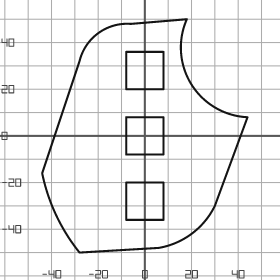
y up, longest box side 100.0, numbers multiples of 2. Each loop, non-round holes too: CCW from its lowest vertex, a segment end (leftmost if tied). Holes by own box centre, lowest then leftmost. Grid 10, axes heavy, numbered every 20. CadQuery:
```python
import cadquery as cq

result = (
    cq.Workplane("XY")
    .moveTo(-28.0, -50.0)
    .lineTo(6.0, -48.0)
    .threePointArc((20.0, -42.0), (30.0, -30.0))
    .lineTo(44.0, 8.0)
    .threePointArc((20.0, 22.0), (18.0, 50.0))
    .lineTo(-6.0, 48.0)
    .threePointArc((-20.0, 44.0), (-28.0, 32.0))
    .lineTo(-44.0, -16.0)
    .threePointArc((-38.0, -34.0), (-28.0, -50.0))
    .close()
    .moveTo(-8.0, -36.0)
    .lineTo(8.0, -36.0)
    .lineTo(8.0, -20.0)
    .lineTo(-8.0, -20.0)
    .close()
    .moveTo(-8.0, -8.0)
    .lineTo(8.0, -8.0)
    .lineTo(8.0, 8.0)
    .lineTo(-8.0, 8.0)
    .close()
    .moveTo(-8.0, 20.0)
    .lineTo(8.0, 20.0)
    .lineTo(8.0, 36.0)
    .lineTo(-8.0, 36.0)
    .close()
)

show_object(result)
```